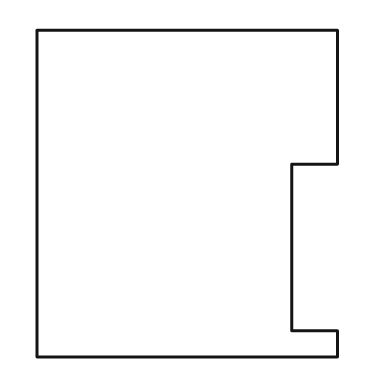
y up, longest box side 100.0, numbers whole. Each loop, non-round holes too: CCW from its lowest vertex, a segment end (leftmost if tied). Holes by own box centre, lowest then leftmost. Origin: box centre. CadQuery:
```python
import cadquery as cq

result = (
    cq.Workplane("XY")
    .moveTo(-46.0, -50.0)
    .lineTo(46.0, -50.0)
    .lineTo(46.0, -42.0)
    .lineTo(32.0, -42.0)
    .lineTo(32.0, 9.0)
    .lineTo(46.0, 9.0)
    .lineTo(46.0, 50.0)
    .lineTo(-46.0, 50.0)
    .close()
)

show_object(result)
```